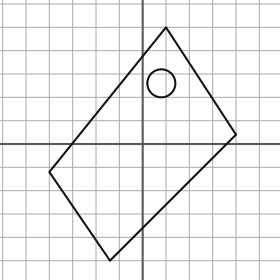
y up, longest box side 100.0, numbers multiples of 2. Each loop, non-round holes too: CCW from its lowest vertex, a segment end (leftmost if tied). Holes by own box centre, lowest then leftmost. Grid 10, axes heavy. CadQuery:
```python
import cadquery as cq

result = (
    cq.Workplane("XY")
    .moveTo(-14.0, -50.0)
    .lineTo(40.0, 4.0)
    .lineTo(10.0, 50.0)
    .lineTo(-40.0, -12.0)
    .close()
    .moveTo(8.0, 26.0)
    .circle(6.0)
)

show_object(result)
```